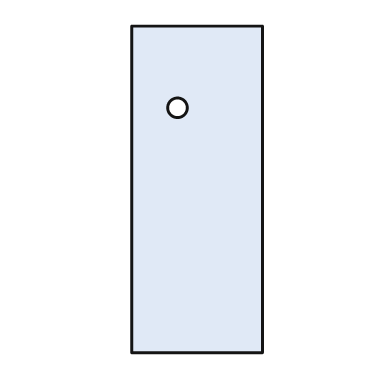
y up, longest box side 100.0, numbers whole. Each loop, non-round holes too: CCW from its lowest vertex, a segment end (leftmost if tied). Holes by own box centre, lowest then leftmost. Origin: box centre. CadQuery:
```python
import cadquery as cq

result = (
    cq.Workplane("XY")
    .moveTo(-20.0, -50.0)
    .lineTo(20.0, -50.0)
    .lineTo(20.0, 50.0)
    .lineTo(-20.0, 50.0)
    .close()
    .moveTo(-6.0, 25.0)
    .circle(3.0)
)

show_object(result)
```